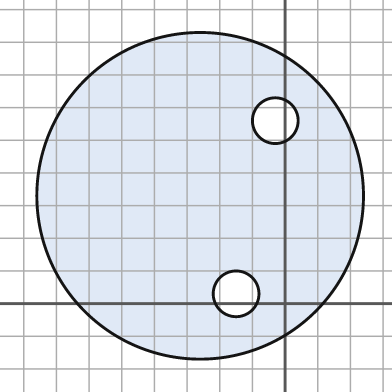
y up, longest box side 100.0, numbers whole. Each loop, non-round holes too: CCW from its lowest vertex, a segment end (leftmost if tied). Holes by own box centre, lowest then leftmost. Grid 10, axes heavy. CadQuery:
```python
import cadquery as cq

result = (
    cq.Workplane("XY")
    .moveTo(-26.0, 33.0)
    .circle(50.0)
    .moveTo(-15.0, 3.0)
    .circle(7.0)
    .moveTo(-3.0, 56.0)
    .circle(7.0)
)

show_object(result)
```